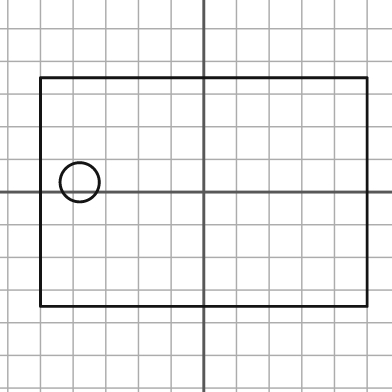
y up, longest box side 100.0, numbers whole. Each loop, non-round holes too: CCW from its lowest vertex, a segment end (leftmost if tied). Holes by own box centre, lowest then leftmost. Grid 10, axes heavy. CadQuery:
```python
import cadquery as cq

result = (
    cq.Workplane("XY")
    .moveTo(-50.0, -35.0)
    .lineTo(50.0, -35.0)
    .lineTo(50.0, 35.0)
    .lineTo(-50.0, 35.0)
    .close()
    .moveTo(-38.0, 3.0)
    .circle(6.0)
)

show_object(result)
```